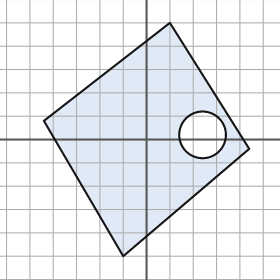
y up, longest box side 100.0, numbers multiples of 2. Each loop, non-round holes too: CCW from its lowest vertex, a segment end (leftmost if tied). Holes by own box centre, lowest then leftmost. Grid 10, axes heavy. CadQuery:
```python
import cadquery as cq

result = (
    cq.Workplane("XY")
    .moveTo(-10.0, -50.0)
    .lineTo(44.0, -4.0)
    .lineTo(10.0, 50.0)
    .lineTo(-44.0, 8.0)
    .close()
    .moveTo(24.0, 2.0)
    .circle(10.0)
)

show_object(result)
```